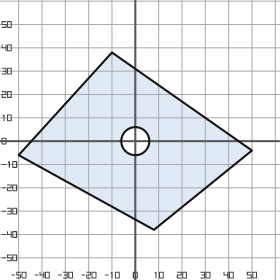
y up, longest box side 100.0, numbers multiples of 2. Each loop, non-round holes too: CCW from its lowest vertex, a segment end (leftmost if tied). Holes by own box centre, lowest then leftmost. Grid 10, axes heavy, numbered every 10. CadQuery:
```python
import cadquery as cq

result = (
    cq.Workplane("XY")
    .moveTo(8.0, -38.0)
    .lineTo(50.0, -4.0)
    .lineTo(-10.0, 38.0)
    .lineTo(-50.0, -6.0)
    .close()
    .moveTo(0.0, 0.0)
    .circle(6.0)
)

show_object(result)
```